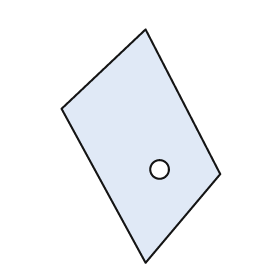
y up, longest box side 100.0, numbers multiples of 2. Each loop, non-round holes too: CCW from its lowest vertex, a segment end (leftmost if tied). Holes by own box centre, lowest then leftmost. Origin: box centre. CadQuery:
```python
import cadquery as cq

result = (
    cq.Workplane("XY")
    .moveTo(2.0, -50.0)
    .lineTo(34.0, -12.0)
    .lineTo(2.0, 50.0)
    .lineTo(-34.0, 16.0)
    .close()
    .moveTo(8.0, -10.0)
    .circle(4.0)
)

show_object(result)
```